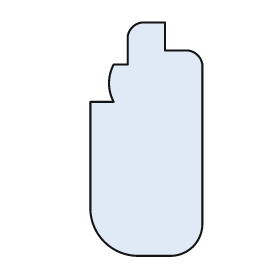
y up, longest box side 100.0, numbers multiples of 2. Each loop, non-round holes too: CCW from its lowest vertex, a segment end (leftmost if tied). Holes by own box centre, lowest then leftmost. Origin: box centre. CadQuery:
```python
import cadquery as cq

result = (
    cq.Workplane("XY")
    .moveTo(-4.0, -50.0)
    .lineTo(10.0, -50.0)
    .threePointArc((20.0, -46.0), (24.0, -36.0))
    .lineTo(24.0, 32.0)
    .threePointArc((22.0, 36.0), (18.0, 38.0))
    .lineTo(8.0, 38.0)
    .lineTo(8.0, 50.0)
    .lineTo(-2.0, 50.0)
    .threePointArc((-6.0, 48.0), (-8.0, 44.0))
    .lineTo(-8.0, 32.0)
    .lineTo(-14.0, 32.0)
    .threePointArc((-16.0, 24.0), (-14.0, 16.0))
    .lineTo(-24.0, 16.0)
    .lineTo(-24.0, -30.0)
    .threePointArc((-18.0, -44.0), (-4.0, -50.0))
    .close()
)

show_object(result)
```